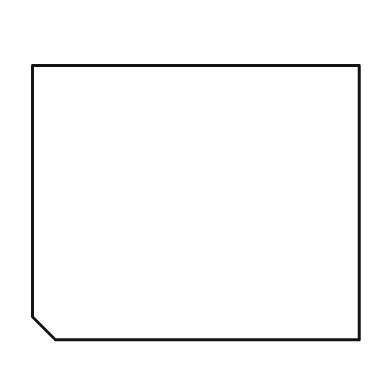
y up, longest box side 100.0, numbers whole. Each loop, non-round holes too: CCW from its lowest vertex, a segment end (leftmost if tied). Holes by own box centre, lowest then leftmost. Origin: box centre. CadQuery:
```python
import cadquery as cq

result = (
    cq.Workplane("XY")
    .moveTo(-43.0, -42.0)
    .lineTo(50.0, -42.0)
    .lineTo(50.0, 42.0)
    .lineTo(-50.0, 42.0)
    .lineTo(-50.0, -35.0)
    .close()
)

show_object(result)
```